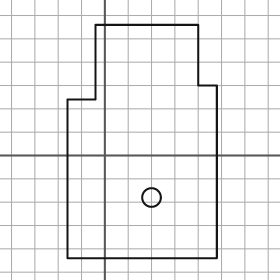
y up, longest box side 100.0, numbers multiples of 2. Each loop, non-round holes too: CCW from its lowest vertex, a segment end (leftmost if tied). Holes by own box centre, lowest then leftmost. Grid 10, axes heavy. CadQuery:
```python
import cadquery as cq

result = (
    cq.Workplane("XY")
    .moveTo(-16.0, -44.0)
    .lineTo(48.0, -44.0)
    .lineTo(48.0, 30.0)
    .lineTo(40.0, 30.0)
    .lineTo(40.0, 56.0)
    .lineTo(-4.0, 56.0)
    .lineTo(-4.0, 24.0)
    .lineTo(-16.0, 24.0)
    .close()
    .moveTo(20.0, -18.0)
    .circle(4.0)
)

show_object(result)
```